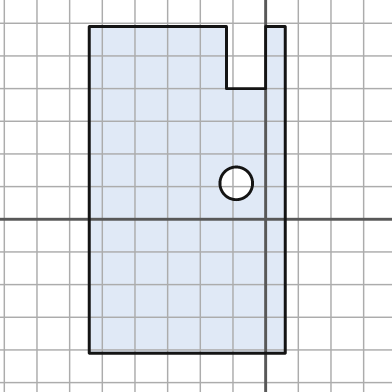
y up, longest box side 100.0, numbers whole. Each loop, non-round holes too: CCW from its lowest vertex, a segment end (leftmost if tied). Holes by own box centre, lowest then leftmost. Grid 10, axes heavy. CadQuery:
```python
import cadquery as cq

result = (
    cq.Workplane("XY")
    .moveTo(-54.0, -41.0)
    .lineTo(6.0, -41.0)
    .lineTo(6.0, 59.0)
    .lineTo(0.0, 59.0)
    .lineTo(0.0, 40.0)
    .lineTo(-12.0, 40.0)
    .lineTo(-12.0, 59.0)
    .lineTo(-54.0, 59.0)
    .close()
    .moveTo(-9.0, 11.0)
    .circle(5.0)
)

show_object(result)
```